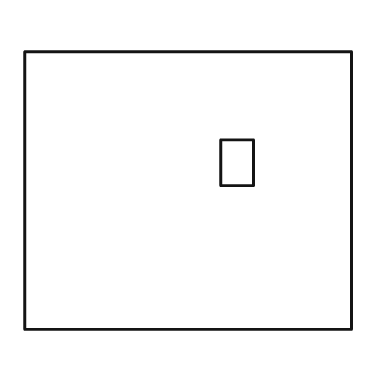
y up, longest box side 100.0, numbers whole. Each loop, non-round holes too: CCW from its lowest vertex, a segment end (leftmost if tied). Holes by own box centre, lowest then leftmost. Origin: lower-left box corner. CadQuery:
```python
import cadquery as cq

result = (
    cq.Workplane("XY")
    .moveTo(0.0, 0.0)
    .lineTo(100.0, 0.0)
    .lineTo(100.0, 85.0)
    .lineTo(0.0, 85.0)
    .close()
    .moveTo(60.0, 44.0)
    .lineTo(70.0, 44.0)
    .lineTo(70.0, 58.0)
    .lineTo(60.0, 58.0)
    .close()
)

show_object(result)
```